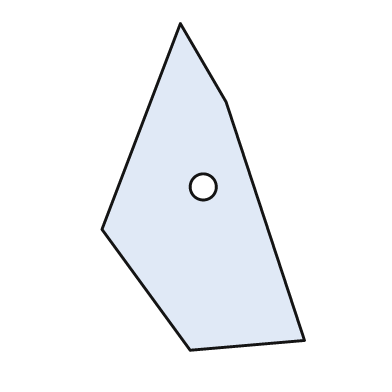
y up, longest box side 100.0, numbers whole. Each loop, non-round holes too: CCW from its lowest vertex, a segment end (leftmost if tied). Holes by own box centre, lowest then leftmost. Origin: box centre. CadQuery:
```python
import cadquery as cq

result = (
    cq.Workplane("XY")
    .moveTo(-4.0, -50.0)
    .lineTo(31.0, -47.0)
    .lineTo(7.0, 26.0)
    .lineTo(-7.0, 50.0)
    .lineTo(-31.0, -13.0)
    .close()
    .moveTo(0.0, 0.0)
    .circle(4.0)
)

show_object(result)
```